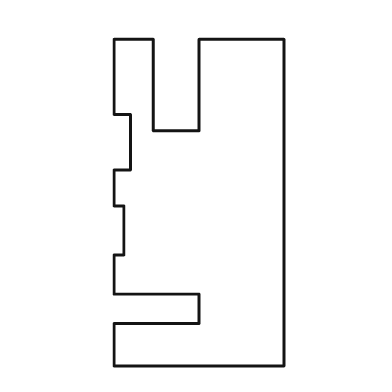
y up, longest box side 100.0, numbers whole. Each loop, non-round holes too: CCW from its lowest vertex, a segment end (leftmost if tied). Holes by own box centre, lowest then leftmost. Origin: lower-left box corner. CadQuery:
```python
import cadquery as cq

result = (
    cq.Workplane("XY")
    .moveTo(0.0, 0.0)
    .lineTo(52.0, 0.0)
    .lineTo(52.0, 100.0)
    .lineTo(26.0, 100.0)
    .lineTo(26.0, 72.0)
    .lineTo(12.0, 72.0)
    .lineTo(12.0, 100.0)
    .lineTo(0.0, 100.0)
    .lineTo(0.0, 77.0)
    .lineTo(5.0, 77.0)
    .lineTo(5.0, 60.0)
    .lineTo(0.0, 60.0)
    .lineTo(0.0, 49.0)
    .lineTo(3.0, 49.0)
    .lineTo(3.0, 34.0)
    .lineTo(0.0, 34.0)
    .lineTo(0.0, 22.0)
    .lineTo(26.0, 22.0)
    .lineTo(26.0, 13.0)
    .lineTo(0.0, 13.0)
    .close()
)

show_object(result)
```